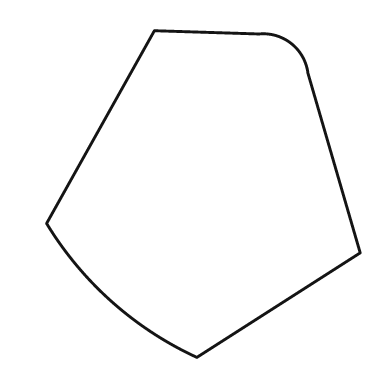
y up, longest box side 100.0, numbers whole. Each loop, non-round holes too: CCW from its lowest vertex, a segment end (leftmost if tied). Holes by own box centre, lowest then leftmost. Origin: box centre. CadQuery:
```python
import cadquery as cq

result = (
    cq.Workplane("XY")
    .moveTo(-2.0, -50.0)
    .lineTo(48.0, -18.0)
    .lineTo(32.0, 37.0)
    .threePointArc((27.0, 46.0), (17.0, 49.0))
    .lineTo(-15.0, 50.0)
    .lineTo(-48.0, -9.0)
    .threePointArc((-28.0, -33.0), (-2.0, -50.0))
    .close()
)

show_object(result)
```